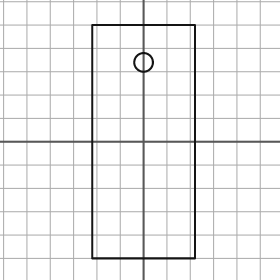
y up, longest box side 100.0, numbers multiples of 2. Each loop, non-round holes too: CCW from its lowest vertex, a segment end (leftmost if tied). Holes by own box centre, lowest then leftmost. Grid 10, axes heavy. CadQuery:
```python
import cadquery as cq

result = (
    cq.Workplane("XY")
    .moveTo(-22.0, -50.0)
    .lineTo(22.0, -50.0)
    .lineTo(22.0, 50.0)
    .lineTo(-22.0, 50.0)
    .close()
    .moveTo(0.0, 34.0)
    .circle(4.0)
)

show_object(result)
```